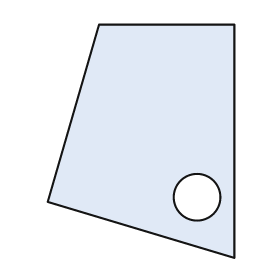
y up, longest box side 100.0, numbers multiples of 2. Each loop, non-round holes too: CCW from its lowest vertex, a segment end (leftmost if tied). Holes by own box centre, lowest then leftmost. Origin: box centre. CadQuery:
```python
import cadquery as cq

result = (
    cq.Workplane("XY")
    .moveTo(40.0, -50.0)
    .lineTo(40.0, 50.0)
    .lineTo(-18.0, 50.0)
    .lineTo(-40.0, -26.0)
    .close()
    .moveTo(24.0, -24.0)
    .circle(10.0)
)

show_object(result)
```